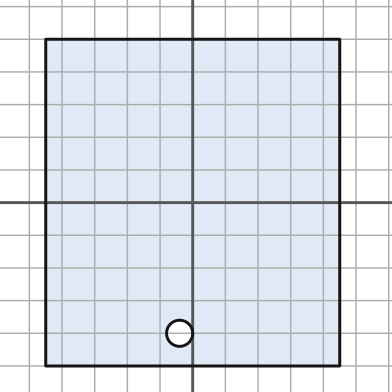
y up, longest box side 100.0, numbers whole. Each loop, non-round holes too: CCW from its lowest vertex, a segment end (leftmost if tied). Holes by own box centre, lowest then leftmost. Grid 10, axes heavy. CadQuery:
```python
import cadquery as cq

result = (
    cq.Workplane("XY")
    .moveTo(-45.0, -50.0)
    .lineTo(45.0, -50.0)
    .lineTo(45.0, 50.0)
    .lineTo(-45.0, 50.0)
    .close()
    .moveTo(-4.0, -40.0)
    .circle(4.0)
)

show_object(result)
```